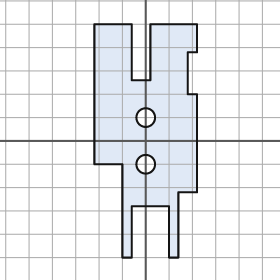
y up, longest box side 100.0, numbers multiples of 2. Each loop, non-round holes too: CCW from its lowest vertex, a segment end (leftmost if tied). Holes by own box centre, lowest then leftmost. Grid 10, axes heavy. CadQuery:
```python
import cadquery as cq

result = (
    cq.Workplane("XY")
    .moveTo(-10.0, -50.0)
    .lineTo(-6.0, -50.0)
    .lineTo(-6.0, -28.0)
    .lineTo(10.0, -28.0)
    .lineTo(10.0, -50.0)
    .lineTo(14.0, -50.0)
    .lineTo(14.0, -22.0)
    .lineTo(22.0, -22.0)
    .lineTo(22.0, 20.0)
    .lineTo(18.0, 20.0)
    .lineTo(18.0, 38.0)
    .lineTo(22.0, 38.0)
    .lineTo(22.0, 50.0)
    .lineTo(2.0, 50.0)
    .lineTo(2.0, 26.0)
    .lineTo(-6.0, 26.0)
    .lineTo(-6.0, 50.0)
    .lineTo(-22.0, 50.0)
    .lineTo(-22.0, -10.0)
    .lineTo(-10.0, -10.0)
    .close()
    .moveTo(0.0, -10.0)
    .circle(4.0)
    .moveTo(0.0, 10.0)
    .circle(4.0)
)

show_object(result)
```